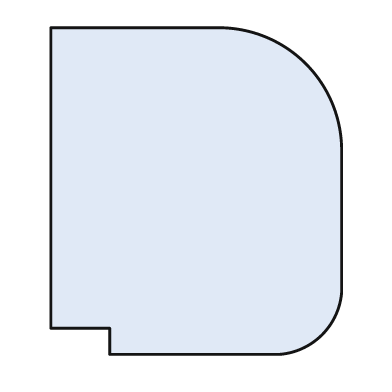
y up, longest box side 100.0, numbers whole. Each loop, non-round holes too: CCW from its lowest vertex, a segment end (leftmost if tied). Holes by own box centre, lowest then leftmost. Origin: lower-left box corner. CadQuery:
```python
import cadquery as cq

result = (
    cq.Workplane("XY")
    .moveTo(18.0, 0.0)
    .lineTo(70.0, 0.0)
    .threePointArc((83.0, 6.0), (89.0, 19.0))
    .lineTo(89.0, 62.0)
    .threePointArc((78.0, 89.0), (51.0, 100.0))
    .lineTo(0.0, 100.0)
    .lineTo(0.0, 8.0)
    .lineTo(18.0, 8.0)
    .close()
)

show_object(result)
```